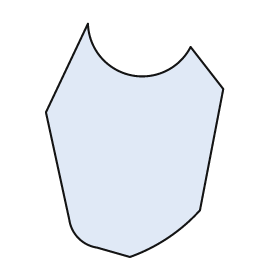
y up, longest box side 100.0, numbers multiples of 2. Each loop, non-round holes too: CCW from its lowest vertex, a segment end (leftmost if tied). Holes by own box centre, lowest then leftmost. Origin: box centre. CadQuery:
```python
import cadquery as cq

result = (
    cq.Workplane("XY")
    .moveTo(-2.0, -50.0)
    .threePointArc((14.0, -42.0), (28.0, -30.0))
    .lineTo(38.0, 22.0)
    .lineTo(24.0, 40.0)
    .threePointArc((-2.0, 28.0), (-20.0, 50.0))
    .lineTo(-38.0, 12.0)
    .lineTo(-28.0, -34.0)
    .threePointArc((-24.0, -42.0), (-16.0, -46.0))
    .close()
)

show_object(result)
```